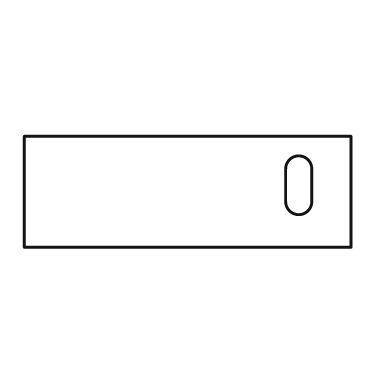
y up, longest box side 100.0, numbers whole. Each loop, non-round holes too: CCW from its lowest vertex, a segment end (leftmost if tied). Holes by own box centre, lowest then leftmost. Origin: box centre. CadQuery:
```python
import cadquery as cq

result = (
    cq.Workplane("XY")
    .moveTo(-50.0, -17.0)
    .lineTo(50.0, -17.0)
    .lineTo(50.0, 17.0)
    .lineTo(-50.0, 17.0)
    .close()
    .moveTo(30.0, -3.0)
    .threePointArc((34.0, -7.0), (38.0, -3.0))
    .lineTo(38.0, 7.0)
    .threePointArc((34.0, 11.0), (30.0, 7.0))
    .close()
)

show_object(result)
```